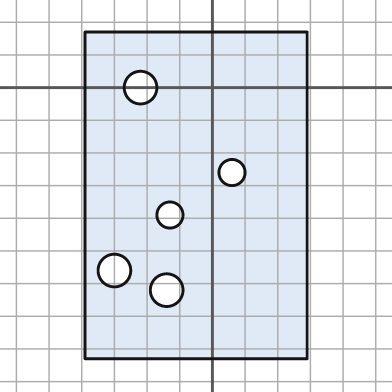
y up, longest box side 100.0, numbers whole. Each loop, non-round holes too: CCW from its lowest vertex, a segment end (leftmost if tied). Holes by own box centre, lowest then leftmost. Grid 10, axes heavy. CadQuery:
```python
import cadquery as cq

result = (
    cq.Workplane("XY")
    .moveTo(-39.0, -83.0)
    .lineTo(29.0, -83.0)
    .lineTo(29.0, 17.0)
    .lineTo(-39.0, 17.0)
    .close()
    .moveTo(-14.0, -62.0)
    .circle(5.0)
    .moveTo(-30.0, -56.0)
    .circle(5.0)
    .moveTo(-13.0, -39.0)
    .circle(4.0)
    .moveTo(6.0, -26.0)
    .circle(4.0)
    .moveTo(-22.0, 0.0)
    .circle(5.0)
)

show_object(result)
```